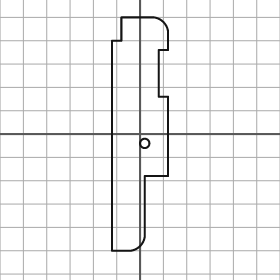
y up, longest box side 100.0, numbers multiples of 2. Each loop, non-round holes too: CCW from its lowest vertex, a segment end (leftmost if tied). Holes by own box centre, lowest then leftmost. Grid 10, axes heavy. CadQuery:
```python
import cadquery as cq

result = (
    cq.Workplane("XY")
    .moveTo(-12.0, -50.0)
    .lineTo(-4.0, -50.0)
    .threePointArc((0.0, -48.0), (2.0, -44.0))
    .lineTo(2.0, -18.0)
    .lineTo(12.0, -18.0)
    .lineTo(12.0, 16.0)
    .lineTo(8.0, 16.0)
    .lineTo(8.0, 36.0)
    .lineTo(12.0, 36.0)
    .lineTo(12.0, 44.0)
    .threePointArc((10.0, 48.0), (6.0, 50.0))
    .lineTo(-8.0, 50.0)
    .lineTo(-8.0, 40.0)
    .lineTo(-12.0, 40.0)
    .close()
    .moveTo(2.0, -4.0)
    .circle(2.0)
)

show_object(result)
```